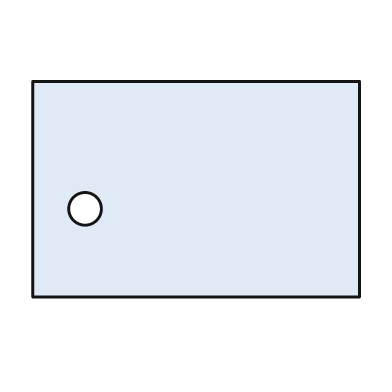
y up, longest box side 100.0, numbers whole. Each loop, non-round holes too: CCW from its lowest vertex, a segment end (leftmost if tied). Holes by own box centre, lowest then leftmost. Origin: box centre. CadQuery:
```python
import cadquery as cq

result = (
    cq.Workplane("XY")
    .moveTo(-50.0, -33.0)
    .lineTo(50.0, -33.0)
    .lineTo(50.0, 33.0)
    .lineTo(-50.0, 33.0)
    .close()
    .moveTo(-34.0, -6.0)
    .circle(5.0)
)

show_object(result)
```